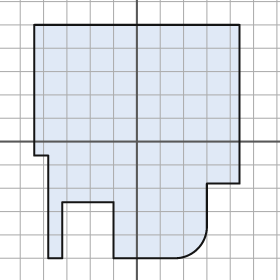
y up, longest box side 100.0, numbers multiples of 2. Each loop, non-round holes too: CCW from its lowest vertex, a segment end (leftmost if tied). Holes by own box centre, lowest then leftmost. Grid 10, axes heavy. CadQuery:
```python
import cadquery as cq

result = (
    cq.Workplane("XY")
    .moveTo(-38.0, -50.0)
    .lineTo(-32.0, -50.0)
    .lineTo(-32.0, -26.0)
    .lineTo(-10.0, -26.0)
    .lineTo(-10.0, -50.0)
    .lineTo(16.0, -50.0)
    .threePointArc((26.0, -46.0), (30.0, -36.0))
    .lineTo(30.0, -18.0)
    .lineTo(44.0, -18.0)
    .lineTo(44.0, 50.0)
    .lineTo(-44.0, 50.0)
    .lineTo(-44.0, -6.0)
    .lineTo(-38.0, -6.0)
    .close()
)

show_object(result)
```